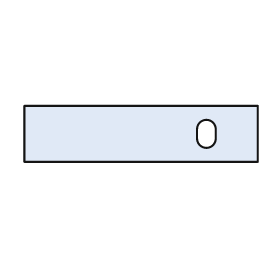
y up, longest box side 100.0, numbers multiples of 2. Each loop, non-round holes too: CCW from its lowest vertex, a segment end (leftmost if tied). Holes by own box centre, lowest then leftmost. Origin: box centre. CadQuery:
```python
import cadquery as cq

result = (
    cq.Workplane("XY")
    .moveTo(-50.0, -12.0)
    .lineTo(50.0, -12.0)
    .lineTo(50.0, 12.0)
    .lineTo(-50.0, 12.0)
    .close()
    .moveTo(24.0, -2.0)
    .threePointArc((28.0, -6.0), (32.0, -2.0))
    .lineTo(32.0, 2.0)
    .threePointArc((28.0, 6.0), (24.0, 2.0))
    .close()
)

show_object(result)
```